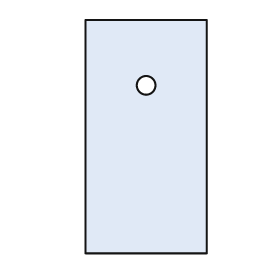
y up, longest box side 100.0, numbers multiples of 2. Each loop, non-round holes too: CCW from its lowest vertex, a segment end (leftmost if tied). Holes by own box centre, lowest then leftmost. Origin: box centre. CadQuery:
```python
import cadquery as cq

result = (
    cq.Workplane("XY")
    .moveTo(-26.0, -50.0)
    .lineTo(26.0, -50.0)
    .lineTo(26.0, 50.0)
    .lineTo(-26.0, 50.0)
    .close()
    .moveTo(0.0, 22.0)
    .circle(4.0)
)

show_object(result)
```